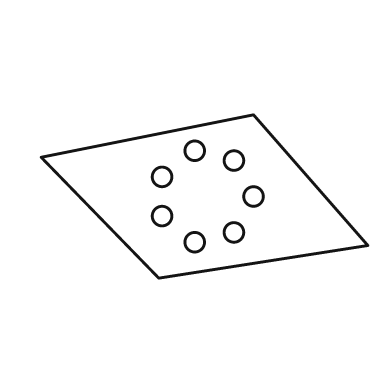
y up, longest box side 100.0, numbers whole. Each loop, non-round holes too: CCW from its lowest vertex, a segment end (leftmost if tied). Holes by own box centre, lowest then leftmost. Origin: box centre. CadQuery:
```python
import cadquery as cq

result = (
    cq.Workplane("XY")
    .moveTo(-14.0, -25.0)
    .lineTo(50.0, -15.0)
    .lineTo(15.0, 25.0)
    .lineTo(-50.0, 12.0)
    .close()
    .moveTo(-3.0, -14.0)
    .circle(3.0)
    .moveTo(9.0, -11.0)
    .circle(3.0)
    .moveTo(-13.0, -6.0)
    .circle(3.0)
    .moveTo(15.0, 0.0)
    .circle(3.0)
    .moveTo(-13.0, 6.0)
    .circle(3.0)
    .moveTo(9.0, 11.0)
    .circle(3.0)
    .moveTo(-3.0, 14.0)
    .circle(3.0)
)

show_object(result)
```